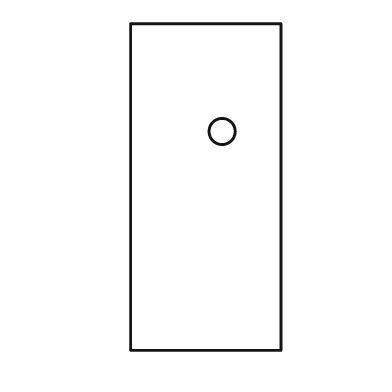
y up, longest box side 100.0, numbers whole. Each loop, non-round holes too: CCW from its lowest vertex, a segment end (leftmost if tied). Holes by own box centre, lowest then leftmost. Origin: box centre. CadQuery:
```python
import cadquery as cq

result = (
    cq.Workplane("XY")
    .moveTo(-23.0, -50.0)
    .lineTo(23.0, -50.0)
    .lineTo(23.0, 50.0)
    .lineTo(-23.0, 50.0)
    .close()
    .moveTo(5.0, 17.0)
    .circle(4.0)
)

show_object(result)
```